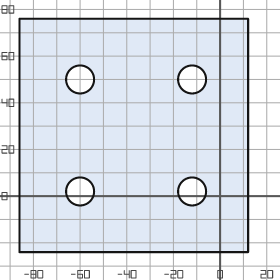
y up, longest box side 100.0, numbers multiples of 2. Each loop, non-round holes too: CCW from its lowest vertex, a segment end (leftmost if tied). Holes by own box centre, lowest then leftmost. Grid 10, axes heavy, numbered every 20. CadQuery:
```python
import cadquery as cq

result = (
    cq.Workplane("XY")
    .moveTo(-86.0, -24.0)
    .lineTo(12.0, -24.0)
    .lineTo(12.0, 76.0)
    .lineTo(-86.0, 76.0)
    .close()
    .moveTo(-60.0, 2.0)
    .circle(6.0)
    .moveTo(-12.0, 2.0)
    .circle(6.0)
    .moveTo(-60.0, 50.0)
    .circle(6.0)
    .moveTo(-12.0, 50.0)
    .circle(6.0)
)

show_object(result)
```